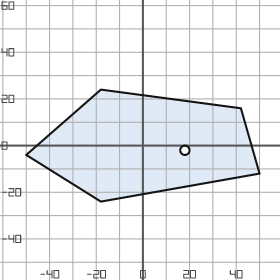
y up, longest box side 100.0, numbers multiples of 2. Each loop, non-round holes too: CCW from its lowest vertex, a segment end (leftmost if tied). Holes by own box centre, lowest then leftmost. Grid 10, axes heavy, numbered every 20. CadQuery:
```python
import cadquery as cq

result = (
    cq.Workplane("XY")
    .moveTo(-18.0, -24.0)
    .lineTo(50.0, -12.0)
    .lineTo(42.0, 16.0)
    .lineTo(-18.0, 24.0)
    .lineTo(-50.0, -4.0)
    .close()
    .moveTo(18.0, -2.0)
    .circle(2.0)
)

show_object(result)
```